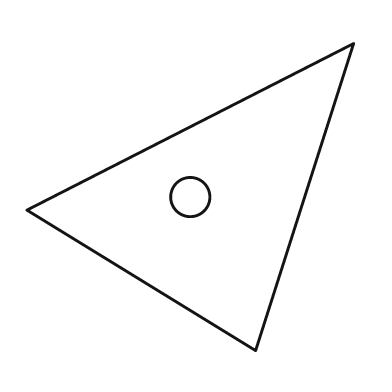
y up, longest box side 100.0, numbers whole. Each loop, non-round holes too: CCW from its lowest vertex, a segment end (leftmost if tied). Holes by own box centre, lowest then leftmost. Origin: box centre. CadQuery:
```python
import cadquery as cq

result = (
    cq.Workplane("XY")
    .moveTo(20.0, -47.0)
    .lineTo(50.0, 47.0)
    .lineTo(-50.0, -4.0)
    .close()
    .moveTo(0.0, 0.0)
    .circle(6.0)
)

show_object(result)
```